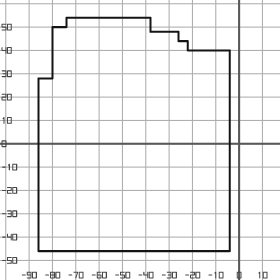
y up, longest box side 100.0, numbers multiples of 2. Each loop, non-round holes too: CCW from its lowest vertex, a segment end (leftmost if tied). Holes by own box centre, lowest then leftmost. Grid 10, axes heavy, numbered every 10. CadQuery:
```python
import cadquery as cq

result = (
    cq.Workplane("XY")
    .moveTo(-86.0, -46.0)
    .lineTo(-4.0, -46.0)
    .lineTo(-4.0, 40.0)
    .lineTo(-22.0, 40.0)
    .lineTo(-22.0, 44.0)
    .lineTo(-26.0, 44.0)
    .lineTo(-26.0, 48.0)
    .lineTo(-38.0, 48.0)
    .lineTo(-38.0, 54.0)
    .lineTo(-74.0, 54.0)
    .lineTo(-74.0, 50.0)
    .lineTo(-80.0, 50.0)
    .lineTo(-80.0, 28.0)
    .lineTo(-86.0, 28.0)
    .close()
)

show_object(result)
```